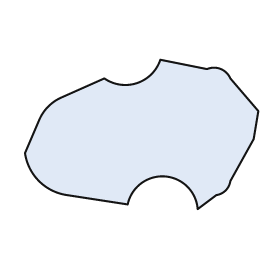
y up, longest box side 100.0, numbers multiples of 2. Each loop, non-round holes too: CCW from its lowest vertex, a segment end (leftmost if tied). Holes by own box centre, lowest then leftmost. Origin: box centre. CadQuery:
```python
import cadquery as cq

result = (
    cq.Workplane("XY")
    .moveTo(24.0, -32.0)
    .lineTo(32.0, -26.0)
    .threePointArc((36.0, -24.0), (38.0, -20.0))
    .lineTo(48.0, -2.0)
    .lineTo(50.0, 10.0)
    .lineTo(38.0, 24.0)
    .threePointArc((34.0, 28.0), (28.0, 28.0))
    .lineTo(8.0, 32.0)
    .threePointArc((-2.0, 22.0), (-16.0, 24.0))
    .lineTo(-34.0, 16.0)
    .threePointArc((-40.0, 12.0), (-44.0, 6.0))
    .lineTo(-50.0, -8.0)
    .threePointArc((-44.0, -20.0), (-32.0, -26.0))
    .lineTo(-6.0, -30.0)
    .threePointArc((10.0, -18.0), (24.0, -32.0))
    .close()
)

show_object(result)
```